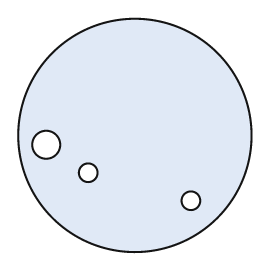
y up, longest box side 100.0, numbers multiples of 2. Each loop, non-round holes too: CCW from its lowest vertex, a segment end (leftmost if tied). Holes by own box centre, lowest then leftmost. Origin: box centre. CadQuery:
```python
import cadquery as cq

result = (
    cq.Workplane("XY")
    .moveTo(0.0, 0.0)
    .circle(50.0)
    .moveTo(24.0, -28.0)
    .circle(4.0)
    .moveTo(-20.0, -16.0)
    .circle(4.0)
    .moveTo(-38.0, -4.0)
    .circle(6.0)
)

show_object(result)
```